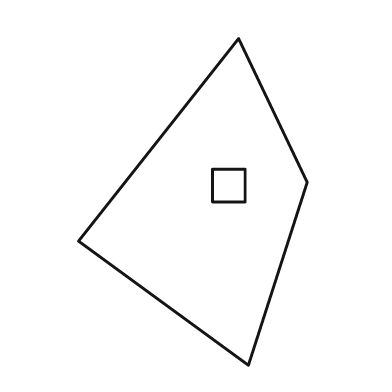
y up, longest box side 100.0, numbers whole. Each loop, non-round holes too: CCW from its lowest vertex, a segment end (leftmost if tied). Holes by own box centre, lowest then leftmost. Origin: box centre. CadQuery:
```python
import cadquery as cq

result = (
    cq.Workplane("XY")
    .moveTo(17.0, -50.0)
    .lineTo(35.0, 6.0)
    .lineTo(14.0, 50.0)
    .lineTo(-35.0, -12.0)
    .close()
    .moveTo(6.0, 0.0)
    .lineTo(16.0, 0.0)
    .lineTo(16.0, 10.0)
    .lineTo(6.0, 10.0)
    .close()
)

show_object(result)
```